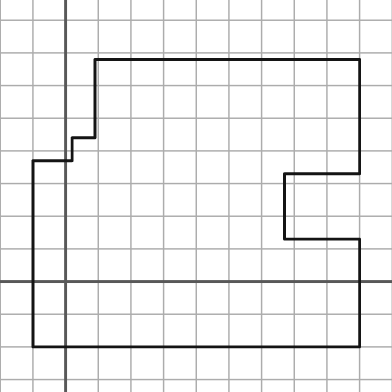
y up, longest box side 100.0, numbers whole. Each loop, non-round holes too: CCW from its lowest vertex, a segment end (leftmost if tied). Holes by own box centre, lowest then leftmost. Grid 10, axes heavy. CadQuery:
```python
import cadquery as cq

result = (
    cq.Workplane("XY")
    .moveTo(-10.0, -20.0)
    .lineTo(90.0, -20.0)
    .lineTo(90.0, 13.0)
    .lineTo(67.0, 13.0)
    .lineTo(67.0, 33.0)
    .lineTo(90.0, 33.0)
    .lineTo(90.0, 68.0)
    .lineTo(9.0, 68.0)
    .lineTo(9.0, 44.0)
    .lineTo(2.0, 44.0)
    .lineTo(2.0, 37.0)
    .lineTo(-10.0, 37.0)
    .close()
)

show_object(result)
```